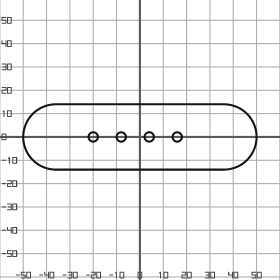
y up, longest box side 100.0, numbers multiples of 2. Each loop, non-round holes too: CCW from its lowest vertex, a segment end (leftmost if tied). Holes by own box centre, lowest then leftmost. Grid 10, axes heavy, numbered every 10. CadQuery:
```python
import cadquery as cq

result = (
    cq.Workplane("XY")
    .moveTo(-36.0, -14.0)
    .lineTo(36.0, -14.0)
    .threePointArc((50.0, 0.0), (36.0, 14.0))
    .lineTo(-36.0, 14.0)
    .threePointArc((-50.0, 0.0), (-36.0, -14.0))
    .close()
    .moveTo(-20.0, 0.0)
    .circle(2.0)
    .moveTo(-8.0, 0.0)
    .circle(2.0)
    .moveTo(4.0, 0.0)
    .circle(2.0)
    .moveTo(16.0, 0.0)
    .circle(2.0)
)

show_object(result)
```